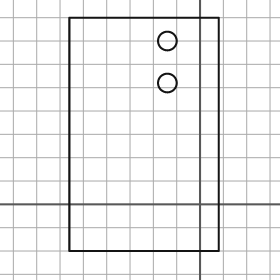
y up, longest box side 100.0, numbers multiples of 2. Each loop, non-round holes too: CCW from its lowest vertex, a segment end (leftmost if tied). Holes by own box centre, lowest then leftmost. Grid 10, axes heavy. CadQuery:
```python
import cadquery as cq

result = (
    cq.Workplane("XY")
    .moveTo(-56.0, -20.0)
    .lineTo(8.0, -20.0)
    .lineTo(8.0, 80.0)
    .lineTo(-56.0, 80.0)
    .close()
    .moveTo(-14.0, 52.0)
    .circle(4.0)
    .moveTo(-14.0, 70.0)
    .circle(4.0)
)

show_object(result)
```